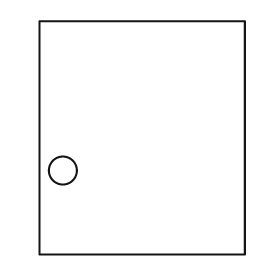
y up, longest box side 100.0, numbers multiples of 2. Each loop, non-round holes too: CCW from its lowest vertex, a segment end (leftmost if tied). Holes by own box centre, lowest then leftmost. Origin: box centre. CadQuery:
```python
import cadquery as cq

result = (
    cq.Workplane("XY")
    .moveTo(-44.0, -50.0)
    .lineTo(44.0, -50.0)
    .lineTo(44.0, 50.0)
    .lineTo(-44.0, 50.0)
    .close()
    .moveTo(-34.0, -14.0)
    .circle(6.0)
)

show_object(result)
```